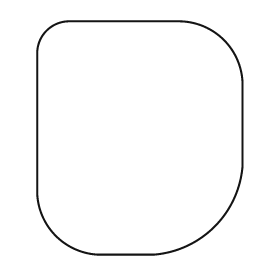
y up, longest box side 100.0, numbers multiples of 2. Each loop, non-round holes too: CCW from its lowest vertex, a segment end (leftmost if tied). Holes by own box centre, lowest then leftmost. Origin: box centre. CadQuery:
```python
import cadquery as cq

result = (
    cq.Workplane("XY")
    .moveTo(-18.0, -50.0)
    .lineTo(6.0, -50.0)
    .threePointArc((32.0, -38.0), (44.0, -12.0))
    .lineTo(44.0, 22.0)
    .threePointArc((36.0, 42.0), (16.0, 50.0))
    .lineTo(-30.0, 50.0)
    .threePointArc((-40.0, 46.0), (-44.0, 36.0))
    .lineTo(-44.0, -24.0)
    .threePointArc((-36.0, -42.0), (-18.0, -50.0))
    .close()
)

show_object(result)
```